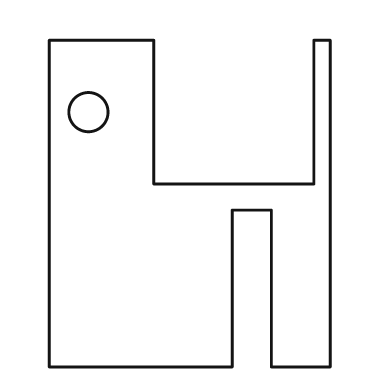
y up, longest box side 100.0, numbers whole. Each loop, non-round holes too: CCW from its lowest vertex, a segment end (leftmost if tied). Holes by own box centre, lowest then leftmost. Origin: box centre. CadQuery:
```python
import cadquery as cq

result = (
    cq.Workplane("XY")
    .moveTo(-43.0, -50.0)
    .lineTo(13.0, -50.0)
    .lineTo(13.0, -2.0)
    .lineTo(25.0, -2.0)
    .lineTo(25.0, -50.0)
    .lineTo(43.0, -50.0)
    .lineTo(43.0, 50.0)
    .lineTo(38.0, 50.0)
    .lineTo(38.0, 6.0)
    .lineTo(-11.0, 6.0)
    .lineTo(-11.0, 50.0)
    .lineTo(-43.0, 50.0)
    .close()
    .moveTo(-31.0, 28.0)
    .circle(6.0)
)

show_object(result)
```